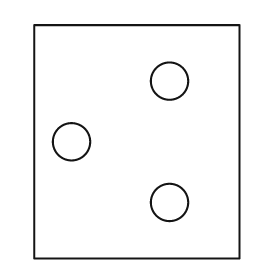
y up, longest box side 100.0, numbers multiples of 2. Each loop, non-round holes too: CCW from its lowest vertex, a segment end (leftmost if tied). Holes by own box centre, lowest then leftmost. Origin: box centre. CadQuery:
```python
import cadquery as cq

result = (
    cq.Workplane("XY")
    .moveTo(-44.0, -50.0)
    .lineTo(44.0, -50.0)
    .lineTo(44.0, 50.0)
    .lineTo(-44.0, 50.0)
    .close()
    .moveTo(14.0, -26.0)
    .circle(8.0)
    .moveTo(-28.0, 0.0)
    .circle(8.0)
    .moveTo(14.0, 26.0)
    .circle(8.0)
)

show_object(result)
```